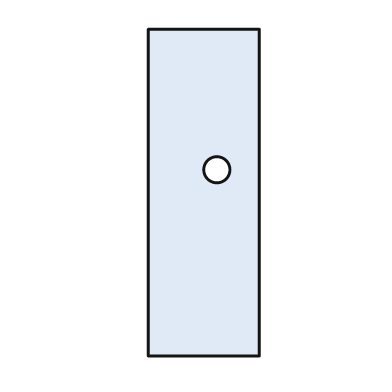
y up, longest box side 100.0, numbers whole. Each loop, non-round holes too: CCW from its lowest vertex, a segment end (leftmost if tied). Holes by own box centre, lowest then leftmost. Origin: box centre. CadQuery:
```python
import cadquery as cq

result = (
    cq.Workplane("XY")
    .moveTo(-17.0, -50.0)
    .lineTo(17.0, -50.0)
    .lineTo(17.0, 50.0)
    .lineTo(-17.0, 50.0)
    .close()
    .moveTo(4.0, 7.0)
    .circle(4.0)
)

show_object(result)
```